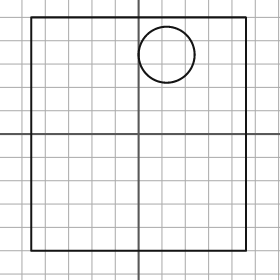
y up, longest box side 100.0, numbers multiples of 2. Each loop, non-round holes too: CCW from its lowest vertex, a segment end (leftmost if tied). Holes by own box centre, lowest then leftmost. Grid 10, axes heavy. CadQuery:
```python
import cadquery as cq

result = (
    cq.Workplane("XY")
    .moveTo(-46.0, -50.0)
    .lineTo(46.0, -50.0)
    .lineTo(46.0, 50.0)
    .lineTo(-46.0, 50.0)
    .close()
    .moveTo(12.0, 34.0)
    .circle(12.0)
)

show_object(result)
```